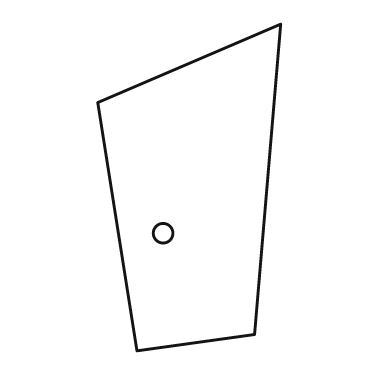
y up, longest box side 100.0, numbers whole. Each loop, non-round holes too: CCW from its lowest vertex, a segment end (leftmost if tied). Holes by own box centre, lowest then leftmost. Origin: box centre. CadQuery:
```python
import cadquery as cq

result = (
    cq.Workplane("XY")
    .moveTo(-16.0, -50.0)
    .lineTo(20.0, -45.0)
    .lineTo(28.0, 50.0)
    .lineTo(-28.0, 26.0)
    .close()
    .moveTo(-8.0, -14.0)
    .circle(3.0)
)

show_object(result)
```